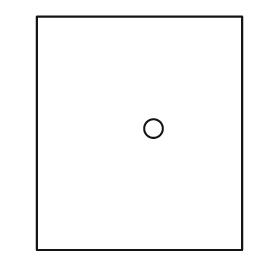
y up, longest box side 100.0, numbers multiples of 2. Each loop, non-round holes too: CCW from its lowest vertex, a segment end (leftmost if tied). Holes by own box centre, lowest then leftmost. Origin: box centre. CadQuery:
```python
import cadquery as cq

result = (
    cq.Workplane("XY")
    .moveTo(-44.0, -50.0)
    .lineTo(44.0, -50.0)
    .lineTo(44.0, 50.0)
    .lineTo(-44.0, 50.0)
    .close()
    .moveTo(6.0, 2.0)
    .circle(4.0)
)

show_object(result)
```